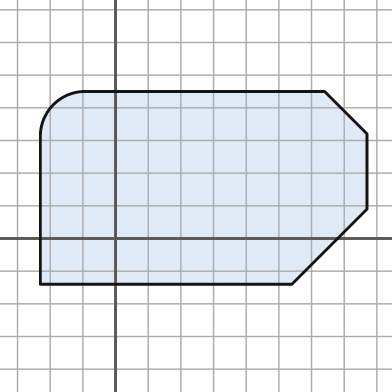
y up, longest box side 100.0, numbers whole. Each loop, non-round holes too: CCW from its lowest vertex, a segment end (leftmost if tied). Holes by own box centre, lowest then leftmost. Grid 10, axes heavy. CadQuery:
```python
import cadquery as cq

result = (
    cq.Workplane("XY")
    .moveTo(-23.0, -14.0)
    .lineTo(54.0, -14.0)
    .lineTo(77.0, 9.0)
    .lineTo(77.0, 32.0)
    .lineTo(64.0, 45.0)
    .lineTo(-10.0, 45.0)
    .threePointArc((-19.0, 41.0), (-23.0, 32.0))
    .close()
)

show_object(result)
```